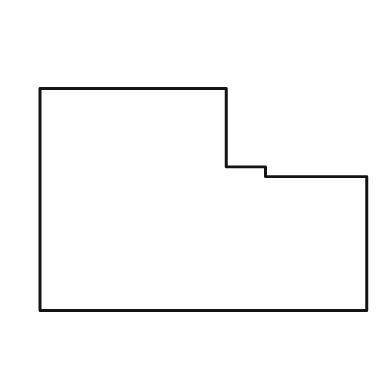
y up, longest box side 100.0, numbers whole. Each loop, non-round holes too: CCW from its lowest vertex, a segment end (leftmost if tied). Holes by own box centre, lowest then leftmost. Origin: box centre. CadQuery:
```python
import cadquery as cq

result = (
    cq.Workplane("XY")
    .moveTo(-50.0, -34.0)
    .lineTo(50.0, -34.0)
    .lineTo(50.0, 7.0)
    .lineTo(19.0, 7.0)
    .lineTo(19.0, 10.0)
    .lineTo(7.0, 10.0)
    .lineTo(7.0, 34.0)
    .lineTo(-50.0, 34.0)
    .close()
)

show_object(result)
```